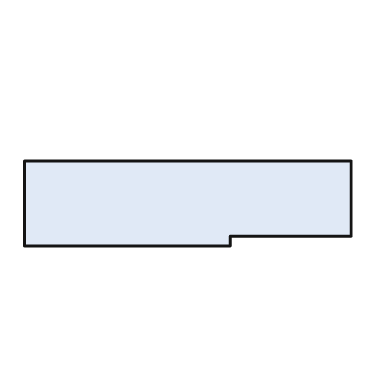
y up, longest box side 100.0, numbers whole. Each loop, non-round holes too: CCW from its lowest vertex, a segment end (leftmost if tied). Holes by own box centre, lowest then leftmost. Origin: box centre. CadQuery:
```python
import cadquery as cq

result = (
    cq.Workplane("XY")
    .moveTo(-50.0, -13.0)
    .lineTo(13.0, -13.0)
    .lineTo(13.0, -10.0)
    .lineTo(50.0, -10.0)
    .lineTo(50.0, 13.0)
    .lineTo(-50.0, 13.0)
    .close()
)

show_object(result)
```